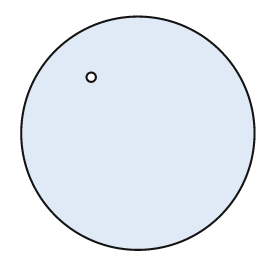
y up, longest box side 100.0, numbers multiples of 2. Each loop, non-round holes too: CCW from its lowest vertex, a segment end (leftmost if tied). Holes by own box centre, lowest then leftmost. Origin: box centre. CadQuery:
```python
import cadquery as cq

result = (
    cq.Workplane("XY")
    .moveTo(0.0, 0.0)
    .circle(50.0)
    .moveTo(-20.0, 24.0)
    .circle(2.0)
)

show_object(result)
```